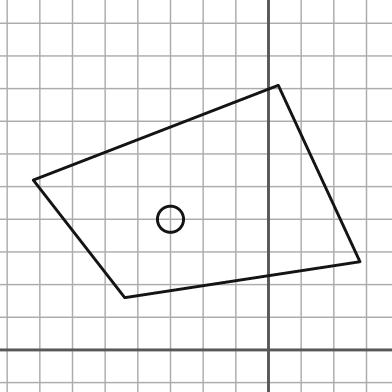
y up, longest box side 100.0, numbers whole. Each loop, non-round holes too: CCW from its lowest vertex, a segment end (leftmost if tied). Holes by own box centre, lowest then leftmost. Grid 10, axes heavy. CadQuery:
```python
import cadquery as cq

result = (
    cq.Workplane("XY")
    .moveTo(-44.0, 16.0)
    .lineTo(28.0, 27.0)
    .lineTo(3.0, 81.0)
    .lineTo(-72.0, 52.0)
    .close()
    .moveTo(-30.0, 40.0)
    .circle(4.0)
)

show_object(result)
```